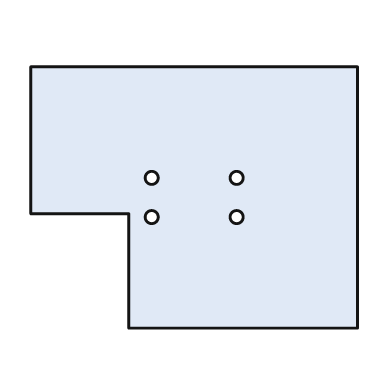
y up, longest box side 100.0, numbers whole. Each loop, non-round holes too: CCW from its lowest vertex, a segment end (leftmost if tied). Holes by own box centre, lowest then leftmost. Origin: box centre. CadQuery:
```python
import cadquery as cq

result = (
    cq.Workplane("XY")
    .moveTo(-20.0, -40.0)
    .lineTo(50.0, -40.0)
    .lineTo(50.0, 40.0)
    .lineTo(-50.0, 40.0)
    .lineTo(-50.0, -5.0)
    .lineTo(-20.0, -5.0)
    .close()
    .moveTo(-13.0, -6.0)
    .circle(2.0)
    .moveTo(13.0, -6.0)
    .circle(2.0)
    .moveTo(-13.0, 6.0)
    .circle(2.0)
    .moveTo(13.0, 6.0)
    .circle(2.0)
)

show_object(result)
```